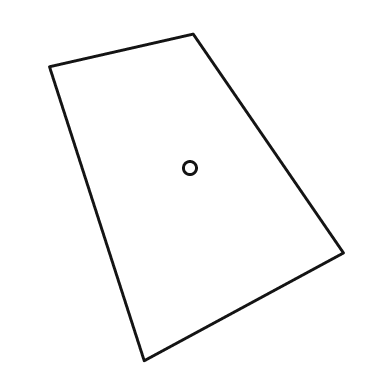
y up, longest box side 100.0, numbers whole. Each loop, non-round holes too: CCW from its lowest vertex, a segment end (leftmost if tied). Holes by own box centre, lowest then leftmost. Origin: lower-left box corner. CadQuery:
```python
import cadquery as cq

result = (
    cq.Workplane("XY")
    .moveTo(29.0, 0.0)
    .lineTo(90.0, 33.0)
    .lineTo(44.0, 100.0)
    .lineTo(0.0, 90.0)
    .close()
    .moveTo(43.0, 59.0)
    .circle(2.0)
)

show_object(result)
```